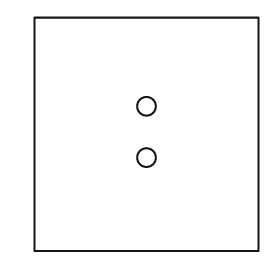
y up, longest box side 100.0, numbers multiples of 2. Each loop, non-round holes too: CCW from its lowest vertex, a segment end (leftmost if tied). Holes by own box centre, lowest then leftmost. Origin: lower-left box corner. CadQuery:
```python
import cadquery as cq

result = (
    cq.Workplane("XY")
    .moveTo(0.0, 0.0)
    .lineTo(96.0, 0.0)
    .lineTo(96.0, 100.0)
    .lineTo(0.0, 100.0)
    .close()
    .moveTo(48.0, 40.0)
    .circle(4.0)
    .moveTo(48.0, 62.0)
    .circle(4.0)
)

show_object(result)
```